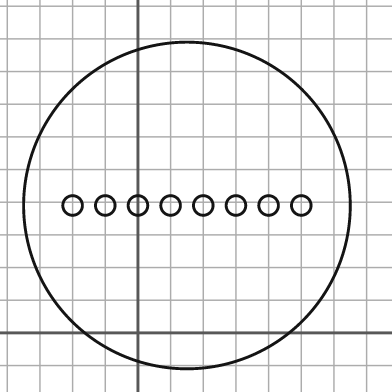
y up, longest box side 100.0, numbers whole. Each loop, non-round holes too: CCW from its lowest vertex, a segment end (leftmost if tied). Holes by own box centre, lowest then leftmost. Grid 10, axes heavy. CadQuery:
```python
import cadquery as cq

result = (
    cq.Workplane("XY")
    .moveTo(15.0, 39.0)
    .circle(50.0)
    .moveTo(-20.0, 39.0)
    .circle(3.0)
    .moveTo(-10.0, 39.0)
    .circle(3.0)
    .moveTo(0.0, 39.0)
    .circle(3.0)
    .moveTo(10.0, 39.0)
    .circle(3.0)
    .moveTo(20.0, 39.0)
    .circle(3.0)
    .moveTo(30.0, 39.0)
    .circle(3.0)
    .moveTo(40.0, 39.0)
    .circle(3.0)
    .moveTo(50.0, 39.0)
    .circle(3.0)
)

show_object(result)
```